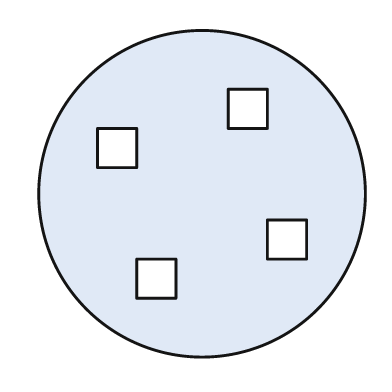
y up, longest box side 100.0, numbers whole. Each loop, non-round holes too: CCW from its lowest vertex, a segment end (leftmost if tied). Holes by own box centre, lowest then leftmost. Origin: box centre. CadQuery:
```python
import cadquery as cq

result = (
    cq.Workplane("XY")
    .moveTo(0.0, 0.0)
    .circle(50.0)
    .moveTo(-20.0, -32.0)
    .lineTo(-8.0, -32.0)
    .lineTo(-8.0, -20.0)
    .lineTo(-20.0, -20.0)
    .close()
    .moveTo(20.0, -20.0)
    .lineTo(32.0, -20.0)
    .lineTo(32.0, -8.0)
    .lineTo(20.0, -8.0)
    .close()
    .moveTo(-32.0, 8.0)
    .lineTo(-20.0, 8.0)
    .lineTo(-20.0, 20.0)
    .lineTo(-32.0, 20.0)
    .close()
    .moveTo(8.0, 20.0)
    .lineTo(20.0, 20.0)
    .lineTo(20.0, 32.0)
    .lineTo(8.0, 32.0)
    .close()
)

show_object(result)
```